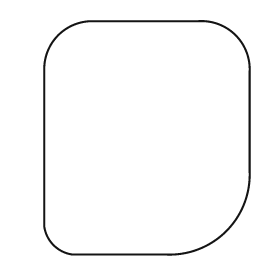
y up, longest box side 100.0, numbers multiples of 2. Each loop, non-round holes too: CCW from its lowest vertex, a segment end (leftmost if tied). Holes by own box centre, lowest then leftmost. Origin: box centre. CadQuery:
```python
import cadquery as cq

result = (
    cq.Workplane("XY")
    .moveTo(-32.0, -50.0)
    .lineTo(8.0, -50.0)
    .threePointArc((34.0, -40.0), (44.0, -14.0))
    .lineTo(44.0, 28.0)
    .threePointArc((38.0, 44.0), (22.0, 50.0))
    .lineTo(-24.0, 50.0)
    .threePointArc((-38.0, 44.0), (-44.0, 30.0))
    .lineTo(-44.0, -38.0)
    .threePointArc((-40.0, -46.0), (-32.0, -50.0))
    .close()
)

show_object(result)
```